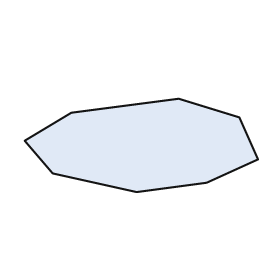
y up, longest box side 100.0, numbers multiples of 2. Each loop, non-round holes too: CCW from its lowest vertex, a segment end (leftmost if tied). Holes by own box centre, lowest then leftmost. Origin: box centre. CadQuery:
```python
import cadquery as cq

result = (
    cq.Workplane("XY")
    .moveTo(-2.0, -20.0)
    .lineTo(28.0, -16.0)
    .lineTo(50.0, -6.0)
    .lineTo(42.0, 12.0)
    .lineTo(16.0, 20.0)
    .lineTo(-30.0, 14.0)
    .lineTo(-50.0, 2.0)
    .lineTo(-38.0, -12.0)
    .close()
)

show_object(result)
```